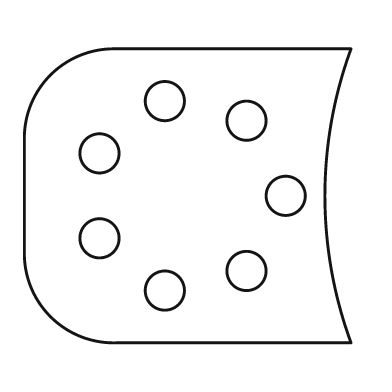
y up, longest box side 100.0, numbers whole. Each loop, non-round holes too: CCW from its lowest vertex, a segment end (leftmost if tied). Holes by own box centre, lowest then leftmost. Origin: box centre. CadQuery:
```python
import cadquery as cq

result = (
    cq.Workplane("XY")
    .moveTo(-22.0, -45.0)
    .lineTo(50.0, -45.0)
    .threePointArc((42.0, 0.0), (50.0, 45.0))
    .lineTo(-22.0, 45.0)
    .threePointArc((-42.0, 37.0), (-50.0, 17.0))
    .lineTo(-50.0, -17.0)
    .threePointArc((-42.0, -37.0), (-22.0, -45.0))
    .close()
    .moveTo(-7.0, -29.0)
    .circle(6.0)
    .moveTo(18.0, -23.0)
    .circle(6.0)
    .moveTo(-27.0, -13.0)
    .circle(6.0)
    .moveTo(30.0, 0.0)
    .circle(6.0)
    .moveTo(-27.0, 13.0)
    .circle(6.0)
    .moveTo(18.0, 23.0)
    .circle(6.0)
    .moveTo(-7.0, 29.0)
    .circle(6.0)
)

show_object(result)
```